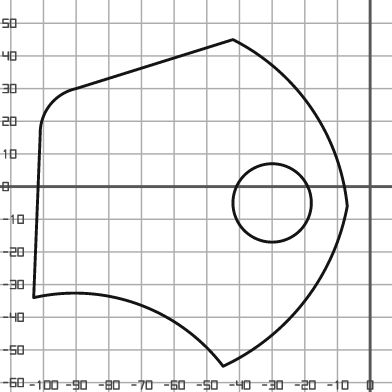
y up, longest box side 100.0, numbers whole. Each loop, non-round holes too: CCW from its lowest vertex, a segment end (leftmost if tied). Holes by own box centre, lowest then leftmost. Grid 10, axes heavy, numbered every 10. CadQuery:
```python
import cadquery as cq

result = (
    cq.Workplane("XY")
    .moveTo(-45.0, -55.0)
    .threePointArc((-20.0, -35.0), (-7.0, -6.0))
    .threePointArc((-18.0, 24.0), (-42.0, 45.0))
    .lineTo(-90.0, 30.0)
    .threePointArc((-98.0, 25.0), (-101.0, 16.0))
    .lineTo(-103.0, -34.0)
    .threePointArc((-71.0, -36.0), (-45.0, -55.0))
    .close()
    .moveTo(-30.0, -5.0)
    .circle(12.0)
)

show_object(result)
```